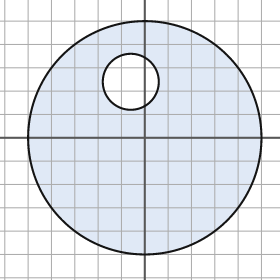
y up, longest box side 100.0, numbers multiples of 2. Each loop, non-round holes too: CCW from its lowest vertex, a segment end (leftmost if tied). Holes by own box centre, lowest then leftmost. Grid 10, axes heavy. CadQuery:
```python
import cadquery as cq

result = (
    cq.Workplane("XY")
    .moveTo(0.0, 0.0)
    .circle(50.0)
    .moveTo(-6.0, 24.0)
    .circle(12.0)
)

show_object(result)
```